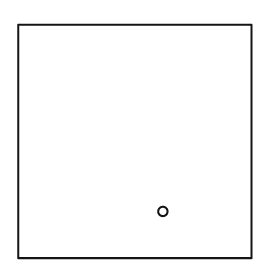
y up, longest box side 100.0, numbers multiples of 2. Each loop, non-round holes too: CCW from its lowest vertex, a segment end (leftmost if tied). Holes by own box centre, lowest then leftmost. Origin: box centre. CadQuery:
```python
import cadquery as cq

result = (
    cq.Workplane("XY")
    .moveTo(-50.0, -50.0)
    .lineTo(50.0, -50.0)
    .lineTo(50.0, 50.0)
    .lineTo(-50.0, 50.0)
    .close()
    .moveTo(12.0, -30.0)
    .circle(2.0)
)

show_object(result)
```